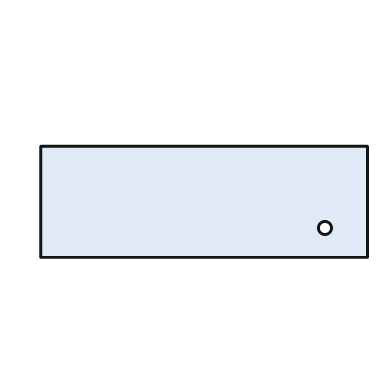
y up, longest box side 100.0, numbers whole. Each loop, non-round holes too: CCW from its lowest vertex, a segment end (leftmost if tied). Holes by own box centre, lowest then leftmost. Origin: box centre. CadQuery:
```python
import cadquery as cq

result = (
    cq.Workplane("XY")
    .moveTo(-50.0, -17.0)
    .lineTo(50.0, -17.0)
    .lineTo(50.0, 17.0)
    .lineTo(-50.0, 17.0)
    .close()
    .moveTo(37.0, -8.0)
    .circle(2.0)
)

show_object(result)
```